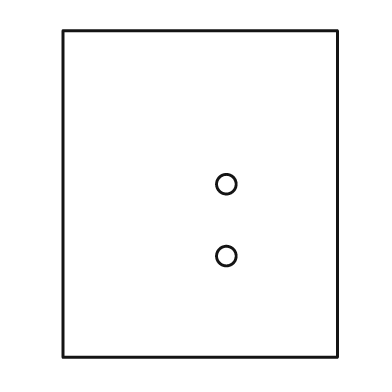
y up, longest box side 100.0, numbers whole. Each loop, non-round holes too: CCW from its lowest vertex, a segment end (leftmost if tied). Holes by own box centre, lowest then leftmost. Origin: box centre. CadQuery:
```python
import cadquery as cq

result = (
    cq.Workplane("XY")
    .moveTo(-42.0, -50.0)
    .lineTo(42.0, -50.0)
    .lineTo(42.0, 50.0)
    .lineTo(-42.0, 50.0)
    .close()
    .moveTo(8.0, -19.0)
    .circle(3.0)
    .moveTo(8.0, 3.0)
    .circle(3.0)
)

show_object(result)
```